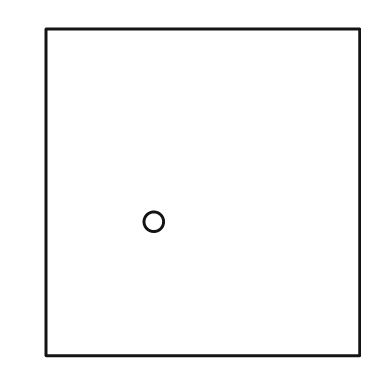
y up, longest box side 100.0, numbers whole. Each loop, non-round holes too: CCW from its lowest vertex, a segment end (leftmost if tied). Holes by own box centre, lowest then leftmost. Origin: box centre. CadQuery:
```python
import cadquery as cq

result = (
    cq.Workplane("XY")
    .moveTo(-48.0, -50.0)
    .lineTo(48.0, -50.0)
    .lineTo(48.0, 50.0)
    .lineTo(-48.0, 50.0)
    .close()
    .moveTo(-15.0, -9.0)
    .circle(3.0)
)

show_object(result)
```